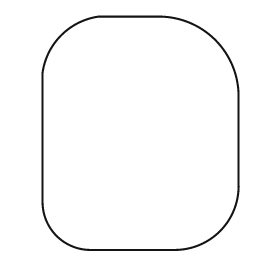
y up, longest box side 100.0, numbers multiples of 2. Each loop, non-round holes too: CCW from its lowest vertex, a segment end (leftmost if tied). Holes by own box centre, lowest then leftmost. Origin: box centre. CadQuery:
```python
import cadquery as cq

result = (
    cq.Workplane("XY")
    .moveTo(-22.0, -50.0)
    .lineTo(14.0, -50.0)
    .threePointArc((34.0, -42.0), (42.0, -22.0))
    .lineTo(42.0, 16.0)
    .threePointArc((32.0, 40.0), (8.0, 50.0))
    .lineTo(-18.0, 50.0)
    .threePointArc((-34.0, 42.0), (-42.0, 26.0))
    .lineTo(-42.0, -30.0)
    .threePointArc((-36.0, -44.0), (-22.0, -50.0))
    .close()
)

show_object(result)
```